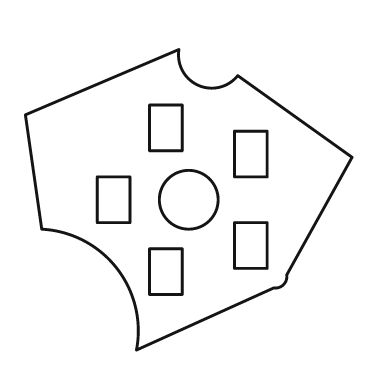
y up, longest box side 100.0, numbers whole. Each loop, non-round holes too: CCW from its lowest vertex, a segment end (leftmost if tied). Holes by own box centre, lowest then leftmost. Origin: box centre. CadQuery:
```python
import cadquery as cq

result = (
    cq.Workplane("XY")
    .moveTo(-16.0, -46.0)
    .lineTo(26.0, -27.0)
    .threePointArc((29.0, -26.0), (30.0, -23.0))
    .lineTo(50.0, 13.0)
    .lineTo(15.0, 38.0)
    .threePointArc((3.0, 35.0), (-3.0, 46.0))
    .lineTo(-50.0, 26.0)
    .lineTo(-45.0, -9.0)
    .threePointArc((-22.0, -21.0), (-16.0, -46.0))
    .close()
    .moveTo(-12.0, -29.0)
    .lineTo(-2.0, -29.0)
    .lineTo(-2.0, -15.0)
    .lineTo(-12.0, -15.0)
    .close()
    .moveTo(14.0, -21.0)
    .lineTo(24.0, -21.0)
    .lineTo(24.0, -7.0)
    .lineTo(14.0, -7.0)
    .close()
    .moveTo(-28.0, -7.0)
    .lineTo(-18.0, -7.0)
    .lineTo(-18.0, 7.0)
    .lineTo(-28.0, 7.0)
    .close()
    .moveTo(0.0, 0.0)
    .circle(9.0)
    .moveTo(14.0, 7.0)
    .lineTo(24.0, 7.0)
    .lineTo(24.0, 21.0)
    .lineTo(14.0, 21.0)
    .close()
    .moveTo(-12.0, 15.0)
    .lineTo(-2.0, 15.0)
    .lineTo(-2.0, 29.0)
    .lineTo(-12.0, 29.0)
    .close()
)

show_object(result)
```